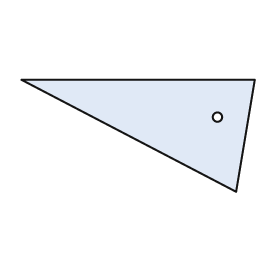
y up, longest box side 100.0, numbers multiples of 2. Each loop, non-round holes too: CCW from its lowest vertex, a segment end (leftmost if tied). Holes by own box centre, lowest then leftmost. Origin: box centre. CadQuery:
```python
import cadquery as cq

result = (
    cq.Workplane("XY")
    .moveTo(42.0, -24.0)
    .lineTo(50.0, 24.0)
    .lineTo(-50.0, 24.0)
    .close()
    .moveTo(34.0, 8.0)
    .circle(2.0)
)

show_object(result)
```